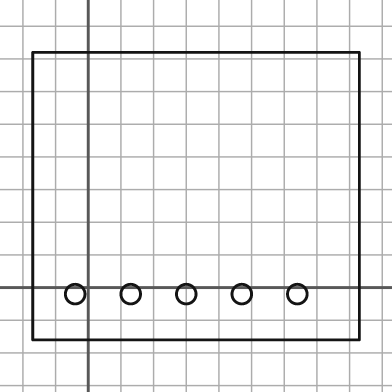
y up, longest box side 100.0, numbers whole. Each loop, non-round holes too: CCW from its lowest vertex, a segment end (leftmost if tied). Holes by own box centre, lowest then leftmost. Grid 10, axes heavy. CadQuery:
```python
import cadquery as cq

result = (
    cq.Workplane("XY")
    .moveTo(-17.0, -16.0)
    .lineTo(83.0, -16.0)
    .lineTo(83.0, 72.0)
    .lineTo(-17.0, 72.0)
    .close()
    .moveTo(-4.0, -2.0)
    .circle(3.0)
    .moveTo(13.0, -2.0)
    .circle(3.0)
    .moveTo(30.0, -2.0)
    .circle(3.0)
    .moveTo(47.0, -2.0)
    .circle(3.0)
    .moveTo(64.0, -2.0)
    .circle(3.0)
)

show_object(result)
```